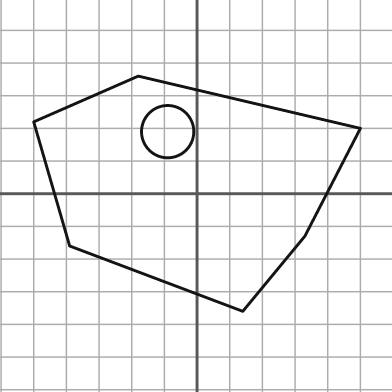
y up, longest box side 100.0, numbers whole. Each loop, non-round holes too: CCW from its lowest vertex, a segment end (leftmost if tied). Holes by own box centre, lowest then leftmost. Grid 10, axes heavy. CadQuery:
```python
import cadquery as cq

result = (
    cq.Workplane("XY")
    .moveTo(14.0, -36.0)
    .lineTo(33.0, -13.0)
    .lineTo(50.0, 20.0)
    .lineTo(-18.0, 36.0)
    .lineTo(-50.0, 22.0)
    .lineTo(-39.0, -16.0)
    .close()
    .moveTo(-9.0, 19.0)
    .circle(8.0)
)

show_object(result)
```